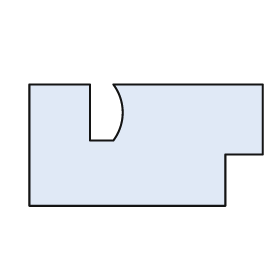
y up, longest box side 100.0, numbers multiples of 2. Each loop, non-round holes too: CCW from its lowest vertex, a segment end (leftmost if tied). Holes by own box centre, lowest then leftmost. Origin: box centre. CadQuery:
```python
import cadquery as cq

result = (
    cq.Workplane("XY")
    .moveTo(-50.0, -26.0)
    .lineTo(34.0, -26.0)
    .lineTo(34.0, -4.0)
    .lineTo(50.0, -4.0)
    .lineTo(50.0, 26.0)
    .lineTo(-14.0, 26.0)
    .threePointArc((-10.0, 14.0), (-14.0, 2.0))
    .lineTo(-24.0, 2.0)
    .lineTo(-24.0, 26.0)
    .lineTo(-50.0, 26.0)
    .close()
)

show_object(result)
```